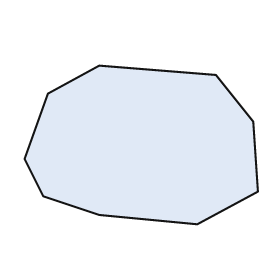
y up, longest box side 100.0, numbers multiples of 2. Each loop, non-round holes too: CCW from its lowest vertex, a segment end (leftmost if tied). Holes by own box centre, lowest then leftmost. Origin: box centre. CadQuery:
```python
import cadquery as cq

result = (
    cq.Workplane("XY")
    .moveTo(24.0, -34.0)
    .lineTo(50.0, -20.0)
    .lineTo(48.0, 10.0)
    .lineTo(32.0, 30.0)
    .lineTo(-18.0, 34.0)
    .lineTo(-40.0, 22.0)
    .lineTo(-50.0, -6.0)
    .lineTo(-42.0, -22.0)
    .lineTo(-18.0, -30.0)
    .close()
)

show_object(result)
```